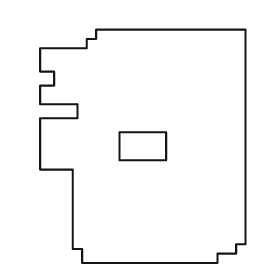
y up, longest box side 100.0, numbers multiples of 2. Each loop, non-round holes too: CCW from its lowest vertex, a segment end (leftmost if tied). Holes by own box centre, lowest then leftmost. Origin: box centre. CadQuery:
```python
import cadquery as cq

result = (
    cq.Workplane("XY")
    .moveTo(-26.0, -50.0)
    .lineTo(32.0, -50.0)
    .lineTo(32.0, -46.0)
    .lineTo(40.0, -46.0)
    .lineTo(40.0, -42.0)
    .lineTo(44.0, -42.0)
    .lineTo(44.0, 50.0)
    .lineTo(-20.0, 50.0)
    .lineTo(-20.0, 46.0)
    .lineTo(-24.0, 46.0)
    .lineTo(-24.0, 42.0)
    .lineTo(-44.0, 42.0)
    .lineTo(-44.0, 32.0)
    .lineTo(-38.0, 32.0)
    .lineTo(-38.0, 26.0)
    .lineTo(-44.0, 26.0)
    .lineTo(-44.0, 18.0)
    .lineTo(-28.0, 18.0)
    .lineTo(-28.0, 12.0)
    .lineTo(-44.0, 12.0)
    .lineTo(-44.0, -10.0)
    .lineTo(-30.0, -10.0)
    .lineTo(-30.0, -44.0)
    .lineTo(-26.0, -44.0)
    .close()
    .moveTo(-10.0, -6.0)
    .lineTo(10.0, -6.0)
    .lineTo(10.0, 6.0)
    .lineTo(-10.0, 6.0)
    .close()
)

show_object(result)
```